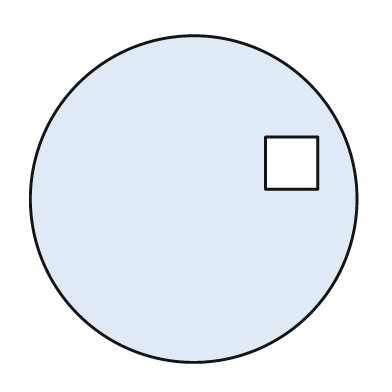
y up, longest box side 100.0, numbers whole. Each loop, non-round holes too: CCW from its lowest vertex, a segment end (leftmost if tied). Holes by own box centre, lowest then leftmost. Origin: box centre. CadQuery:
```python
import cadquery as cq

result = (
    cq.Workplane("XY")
    .moveTo(0.0, 0.0)
    .circle(50.0)
    .moveTo(22.0, 3.0)
    .lineTo(38.0, 3.0)
    .lineTo(38.0, 19.0)
    .lineTo(22.0, 19.0)
    .close()
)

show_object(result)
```